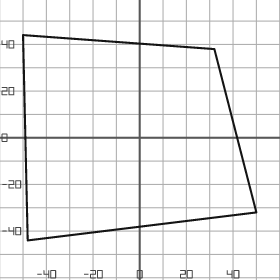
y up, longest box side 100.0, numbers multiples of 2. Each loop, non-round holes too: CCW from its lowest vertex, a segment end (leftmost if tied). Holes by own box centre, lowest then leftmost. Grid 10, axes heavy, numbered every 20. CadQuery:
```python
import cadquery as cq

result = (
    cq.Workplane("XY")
    .moveTo(-48.0, -44.0)
    .lineTo(50.0, -32.0)
    .lineTo(32.0, 38.0)
    .lineTo(-50.0, 44.0)
    .close()
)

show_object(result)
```